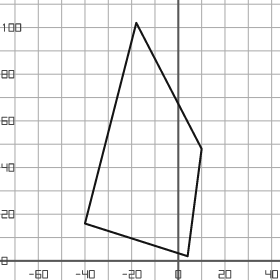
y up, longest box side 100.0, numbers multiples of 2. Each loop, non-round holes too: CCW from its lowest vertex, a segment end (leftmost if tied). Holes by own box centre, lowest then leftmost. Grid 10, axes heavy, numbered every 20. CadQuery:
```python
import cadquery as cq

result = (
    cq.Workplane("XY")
    .moveTo(4.0, 2.0)
    .lineTo(10.0, 48.0)
    .lineTo(-18.0, 102.0)
    .lineTo(-40.0, 16.0)
    .close()
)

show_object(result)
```